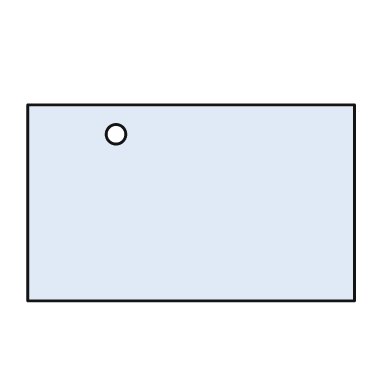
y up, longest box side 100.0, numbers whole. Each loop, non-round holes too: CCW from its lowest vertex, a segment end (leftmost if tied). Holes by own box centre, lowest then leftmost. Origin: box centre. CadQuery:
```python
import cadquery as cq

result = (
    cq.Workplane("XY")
    .moveTo(-50.0, -30.0)
    .lineTo(50.0, -30.0)
    .lineTo(50.0, 30.0)
    .lineTo(-50.0, 30.0)
    .close()
    .moveTo(-23.0, 21.0)
    .circle(3.0)
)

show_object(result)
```